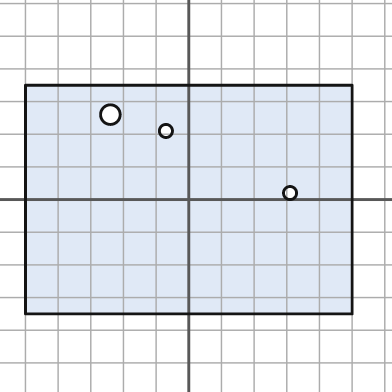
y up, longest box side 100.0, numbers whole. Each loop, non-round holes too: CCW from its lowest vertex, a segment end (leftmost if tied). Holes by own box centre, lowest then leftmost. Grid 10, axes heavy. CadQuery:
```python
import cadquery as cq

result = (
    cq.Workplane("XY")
    .moveTo(-50.0, -35.0)
    .lineTo(50.0, -35.0)
    .lineTo(50.0, 35.0)
    .lineTo(-50.0, 35.0)
    .close()
    .moveTo(31.0, 2.0)
    .circle(2.0)
    .moveTo(-7.0, 21.0)
    .circle(2.0)
    .moveTo(-24.0, 26.0)
    .circle(3.0)
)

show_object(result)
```